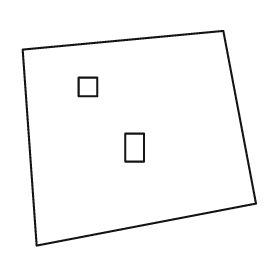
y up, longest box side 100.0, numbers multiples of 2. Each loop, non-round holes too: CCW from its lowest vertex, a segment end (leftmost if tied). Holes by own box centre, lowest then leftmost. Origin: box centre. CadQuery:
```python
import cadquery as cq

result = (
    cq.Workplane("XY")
    .moveTo(-44.0, -46.0)
    .lineTo(50.0, -28.0)
    .lineTo(36.0, 46.0)
    .lineTo(-50.0, 38.0)
    .close()
    .moveTo(-6.0, -10.0)
    .lineTo(2.0, -10.0)
    .lineTo(2.0, 2.0)
    .lineTo(-6.0, 2.0)
    .close()
    .moveTo(-26.0, 18.0)
    .lineTo(-18.0, 18.0)
    .lineTo(-18.0, 26.0)
    .lineTo(-26.0, 26.0)
    .close()
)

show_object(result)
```